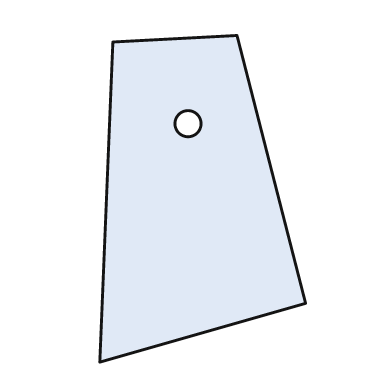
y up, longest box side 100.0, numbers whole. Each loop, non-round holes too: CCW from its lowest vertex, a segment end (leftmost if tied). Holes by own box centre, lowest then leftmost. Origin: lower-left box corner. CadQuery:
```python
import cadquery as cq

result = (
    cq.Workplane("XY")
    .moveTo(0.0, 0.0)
    .lineTo(63.0, 18.0)
    .lineTo(42.0, 100.0)
    .lineTo(4.0, 98.0)
    .close()
    .moveTo(27.0, 73.0)
    .circle(4.0)
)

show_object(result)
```